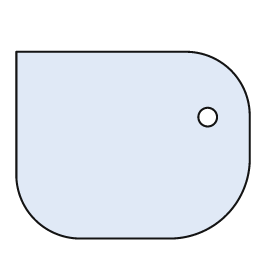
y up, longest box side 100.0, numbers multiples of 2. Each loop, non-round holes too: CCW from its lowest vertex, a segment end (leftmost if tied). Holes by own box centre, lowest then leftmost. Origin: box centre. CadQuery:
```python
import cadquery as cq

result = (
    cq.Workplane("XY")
    .moveTo(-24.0, -40.0)
    .lineTo(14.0, -40.0)
    .threePointArc((40.0, -30.0), (50.0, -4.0))
    .lineTo(50.0, 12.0)
    .threePointArc((42.0, 32.0), (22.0, 40.0))
    .lineTo(-50.0, 40.0)
    .lineTo(-50.0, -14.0)
    .threePointArc((-42.0, -32.0), (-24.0, -40.0))
    .close()
    .moveTo(32.0, 12.0)
    .circle(4.0)
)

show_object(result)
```